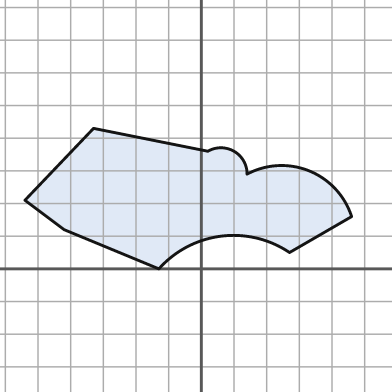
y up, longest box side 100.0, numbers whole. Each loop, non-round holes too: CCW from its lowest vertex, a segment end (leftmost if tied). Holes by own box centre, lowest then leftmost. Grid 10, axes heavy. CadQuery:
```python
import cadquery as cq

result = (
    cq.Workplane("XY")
    .moveTo(-13.0, 0.0)
    .threePointArc((6.0, 10.0), (27.0, 5.0))
    .lineTo(46.0, 16.0)
    .threePointArc((33.0, 30.0), (14.0, 29.0))
    .threePointArc((10.0, 36.0), (2.0, 36.0))
    .lineTo(-33.0, 43.0)
    .lineTo(-54.0, 21.0)
    .lineTo(-42.0, 12.0)
    .close()
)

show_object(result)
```